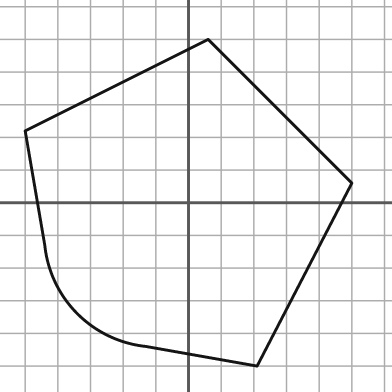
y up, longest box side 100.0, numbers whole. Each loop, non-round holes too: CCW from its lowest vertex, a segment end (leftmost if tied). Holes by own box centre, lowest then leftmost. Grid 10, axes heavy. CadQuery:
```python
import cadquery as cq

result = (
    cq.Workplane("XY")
    .moveTo(21.0, -50.0)
    .lineTo(50.0, 6.0)
    .lineTo(6.0, 50.0)
    .lineTo(-50.0, 22.0)
    .lineTo(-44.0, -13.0)
    .threePointArc((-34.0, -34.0), (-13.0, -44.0))
    .close()
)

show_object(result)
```